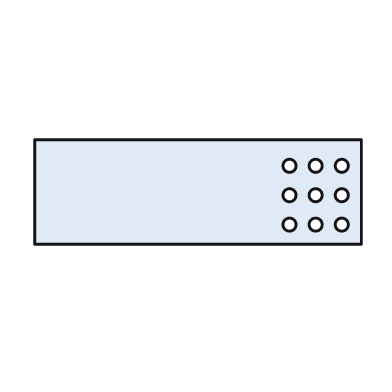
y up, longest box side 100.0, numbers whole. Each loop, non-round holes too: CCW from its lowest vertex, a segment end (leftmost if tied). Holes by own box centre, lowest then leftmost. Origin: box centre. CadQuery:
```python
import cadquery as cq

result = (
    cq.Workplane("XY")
    .moveTo(-50.0, -16.0)
    .lineTo(50.0, -16.0)
    .lineTo(50.0, 16.0)
    .lineTo(-50.0, 16.0)
    .close()
    .moveTo(28.0, -10.0)
    .circle(2.0)
    .moveTo(36.0, -10.0)
    .circle(2.0)
    .moveTo(44.0, -10.0)
    .circle(2.0)
    .moveTo(28.0, -1.0)
    .circle(2.0)
    .moveTo(36.0, -1.0)
    .circle(2.0)
    .moveTo(44.0, -1.0)
    .circle(2.0)
    .moveTo(28.0, 8.0)
    .circle(2.0)
    .moveTo(36.0, 8.0)
    .circle(2.0)
    .moveTo(44.0, 8.0)
    .circle(2.0)
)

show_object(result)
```